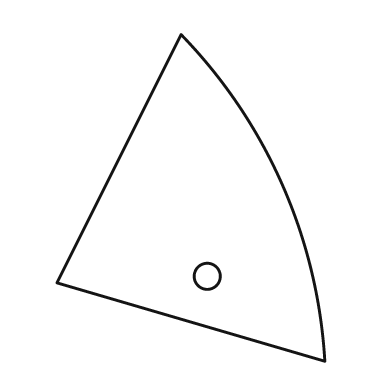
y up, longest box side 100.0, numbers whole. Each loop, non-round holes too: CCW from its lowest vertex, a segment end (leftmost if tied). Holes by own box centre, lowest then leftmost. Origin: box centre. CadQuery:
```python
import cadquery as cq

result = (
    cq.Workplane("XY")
    .moveTo(41.0, -50.0)
    .threePointArc((28.0, 4.0), (-3.0, 50.0))
    .lineTo(-41.0, -26.0)
    .close()
    .moveTo(5.0, -24.0)
    .circle(4.0)
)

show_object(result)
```